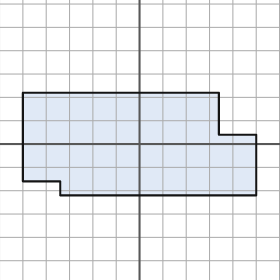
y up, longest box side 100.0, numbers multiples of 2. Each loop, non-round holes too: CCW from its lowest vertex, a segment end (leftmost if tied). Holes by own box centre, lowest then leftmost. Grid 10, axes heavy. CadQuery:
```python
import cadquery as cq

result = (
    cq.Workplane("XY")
    .moveTo(-34.0, -22.0)
    .lineTo(50.0, -22.0)
    .lineTo(50.0, 4.0)
    .lineTo(34.0, 4.0)
    .lineTo(34.0, 22.0)
    .lineTo(-50.0, 22.0)
    .lineTo(-50.0, -16.0)
    .lineTo(-34.0, -16.0)
    .close()
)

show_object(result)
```